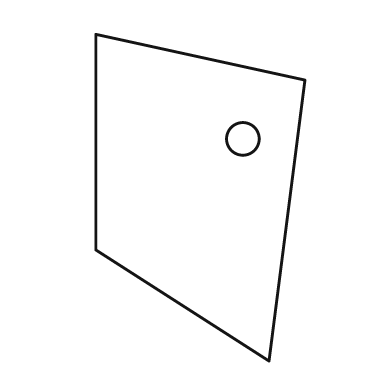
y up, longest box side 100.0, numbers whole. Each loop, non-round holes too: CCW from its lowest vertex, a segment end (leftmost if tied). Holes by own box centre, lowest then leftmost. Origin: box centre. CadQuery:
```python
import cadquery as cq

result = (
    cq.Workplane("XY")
    .moveTo(21.0, -50.0)
    .lineTo(32.0, 36.0)
    .lineTo(-32.0, 50.0)
    .lineTo(-32.0, -16.0)
    .close()
    .moveTo(13.0, 18.0)
    .circle(5.0)
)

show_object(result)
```